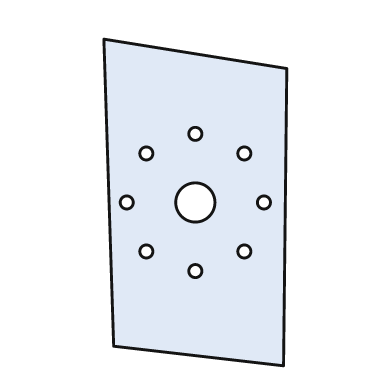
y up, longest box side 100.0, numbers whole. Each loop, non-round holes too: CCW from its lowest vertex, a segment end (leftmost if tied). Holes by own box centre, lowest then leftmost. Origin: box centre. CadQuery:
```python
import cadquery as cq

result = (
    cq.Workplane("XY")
    .moveTo(27.0, -50.0)
    .lineTo(28.0, 41.0)
    .lineTo(-28.0, 50.0)
    .lineTo(-25.0, -44.0)
    .close()
    .moveTo(0.0, -21.0)
    .circle(2.0)
    .moveTo(-15.0, -15.0)
    .circle(2.0)
    .moveTo(15.0, -15.0)
    .circle(2.0)
    .moveTo(-21.0, 0.0)
    .circle(2.0)
    .moveTo(0.0, 0.0)
    .circle(6.0)
    .moveTo(21.0, 0.0)
    .circle(2.0)
    .moveTo(-15.0, 15.0)
    .circle(2.0)
    .moveTo(15.0, 15.0)
    .circle(2.0)
    .moveTo(0.0, 21.0)
    .circle(2.0)
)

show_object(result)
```